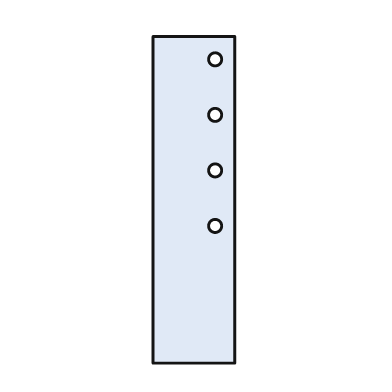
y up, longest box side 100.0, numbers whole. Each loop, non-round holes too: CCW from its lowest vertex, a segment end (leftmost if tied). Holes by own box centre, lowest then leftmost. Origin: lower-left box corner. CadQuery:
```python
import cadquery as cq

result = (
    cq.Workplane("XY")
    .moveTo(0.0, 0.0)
    .lineTo(25.0, 0.0)
    .lineTo(25.0, 100.0)
    .lineTo(0.0, 100.0)
    .close()
    .moveTo(19.0, 42.0)
    .circle(2.0)
    .moveTo(19.0, 59.0)
    .circle(2.0)
    .moveTo(19.0, 76.0)
    .circle(2.0)
    .moveTo(19.0, 93.0)
    .circle(2.0)
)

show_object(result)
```